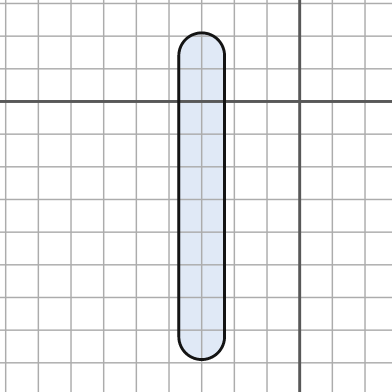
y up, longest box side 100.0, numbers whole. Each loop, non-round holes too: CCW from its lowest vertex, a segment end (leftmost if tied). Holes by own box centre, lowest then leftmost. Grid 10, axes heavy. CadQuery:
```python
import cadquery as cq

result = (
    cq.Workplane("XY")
    .moveTo(-37.0, -72.0)
    .threePointArc((-30.0, -79.0), (-23.0, -72.0))
    .lineTo(-23.0, 14.0)
    .threePointArc((-30.0, 21.0), (-37.0, 14.0))
    .close()
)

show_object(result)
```